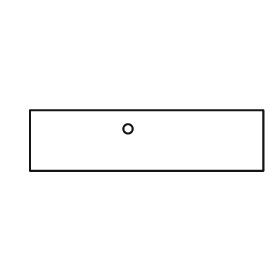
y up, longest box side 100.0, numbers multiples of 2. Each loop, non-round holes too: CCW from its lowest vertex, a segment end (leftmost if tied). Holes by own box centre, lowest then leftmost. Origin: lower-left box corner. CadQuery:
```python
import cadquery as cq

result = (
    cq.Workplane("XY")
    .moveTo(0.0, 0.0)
    .lineTo(100.0, 0.0)
    .lineTo(100.0, 26.0)
    .lineTo(0.0, 26.0)
    .close()
    .moveTo(42.0, 18.0)
    .circle(2.0)
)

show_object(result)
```